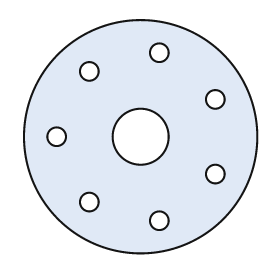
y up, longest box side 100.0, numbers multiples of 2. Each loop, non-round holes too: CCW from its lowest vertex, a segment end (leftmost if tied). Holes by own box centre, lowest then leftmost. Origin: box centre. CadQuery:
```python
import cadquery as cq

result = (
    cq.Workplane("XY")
    .moveTo(0.0, 0.0)
    .circle(50.0)
    .moveTo(8.0, -36.0)
    .circle(4.0)
    .moveTo(-22.0, -28.0)
    .circle(4.0)
    .moveTo(32.0, -16.0)
    .circle(4.0)
    .moveTo(-36.0, 0.0)
    .circle(4.0)
    .moveTo(0.0, 0.0)
    .circle(12.0)
    .moveTo(32.0, 16.0)
    .circle(4.0)
    .moveTo(-22.0, 28.0)
    .circle(4.0)
    .moveTo(8.0, 36.0)
    .circle(4.0)
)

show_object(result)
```